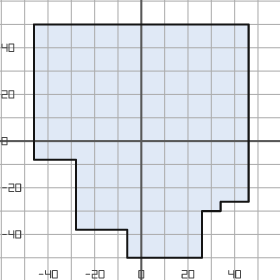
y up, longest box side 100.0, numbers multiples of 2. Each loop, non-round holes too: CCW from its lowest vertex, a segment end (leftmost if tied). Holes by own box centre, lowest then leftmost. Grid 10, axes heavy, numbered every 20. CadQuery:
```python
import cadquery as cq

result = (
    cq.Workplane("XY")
    .moveTo(-6.0, -50.0)
    .lineTo(26.0, -50.0)
    .lineTo(26.0, -30.0)
    .lineTo(34.0, -30.0)
    .lineTo(34.0, -26.0)
    .lineTo(46.0, -26.0)
    .lineTo(46.0, 50.0)
    .lineTo(-46.0, 50.0)
    .lineTo(-46.0, -8.0)
    .lineTo(-28.0, -8.0)
    .lineTo(-28.0, -38.0)
    .lineTo(-6.0, -38.0)
    .close()
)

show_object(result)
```